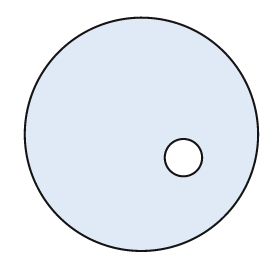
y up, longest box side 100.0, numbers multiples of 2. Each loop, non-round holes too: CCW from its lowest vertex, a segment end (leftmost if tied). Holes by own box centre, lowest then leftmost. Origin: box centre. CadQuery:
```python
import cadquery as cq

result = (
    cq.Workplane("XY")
    .moveTo(0.0, 0.0)
    .circle(50.0)
    .moveTo(18.0, -10.0)
    .circle(8.0)
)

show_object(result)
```